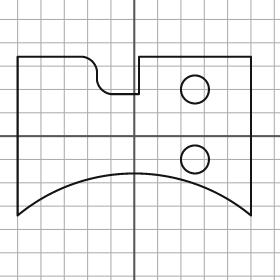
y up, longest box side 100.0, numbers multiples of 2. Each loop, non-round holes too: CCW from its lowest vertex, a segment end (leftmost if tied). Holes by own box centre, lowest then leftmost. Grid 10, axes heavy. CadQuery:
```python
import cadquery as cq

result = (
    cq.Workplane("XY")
    .moveTo(-50.0, -34.0)
    .threePointArc((0.0, -16.0), (50.0, -34.0))
    .lineTo(50.0, 34.0)
    .lineTo(2.0, 34.0)
    .lineTo(2.0, 18.0)
    .lineTo(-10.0, 18.0)
    .threePointArc((-14.0, 20.0), (-16.0, 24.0))
    .lineTo(-16.0, 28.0)
    .threePointArc((-18.0, 32.0), (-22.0, 34.0))
    .lineTo(-50.0, 34.0)
    .close()
    .moveTo(26.0, -10.0)
    .circle(6.0)
    .moveTo(26.0, 20.0)
    .circle(6.0)
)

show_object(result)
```